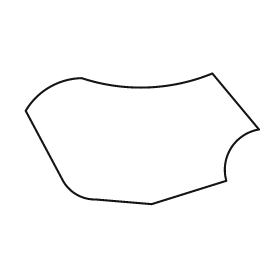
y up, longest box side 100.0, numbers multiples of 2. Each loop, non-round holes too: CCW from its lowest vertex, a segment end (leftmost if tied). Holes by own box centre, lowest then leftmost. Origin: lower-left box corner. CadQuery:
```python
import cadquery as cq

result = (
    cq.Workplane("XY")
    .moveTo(54.0, 0.0)
    .lineTo(86.0, 10.0)
    .threePointArc((88.0, 24.0), (100.0, 32.0))
    .lineTo(80.0, 56.0)
    .threePointArc((52.0, 50.0), (24.0, 54.0))
    .threePointArc((10.0, 50.0), (0.0, 40.0))
    .lineTo(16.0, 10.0)
    .threePointArc((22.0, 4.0), (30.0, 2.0))
    .close()
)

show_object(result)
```